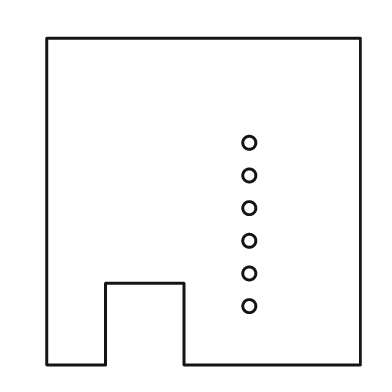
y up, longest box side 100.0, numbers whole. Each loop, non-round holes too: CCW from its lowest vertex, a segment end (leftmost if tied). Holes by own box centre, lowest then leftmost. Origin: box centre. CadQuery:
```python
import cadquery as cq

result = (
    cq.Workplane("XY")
    .moveTo(-48.0, -50.0)
    .lineTo(-30.0, -50.0)
    .lineTo(-30.0, -25.0)
    .lineTo(-6.0, -25.0)
    .lineTo(-6.0, -50.0)
    .lineTo(48.0, -50.0)
    .lineTo(48.0, 50.0)
    .lineTo(-48.0, 50.0)
    .close()
    .moveTo(14.0, -32.0)
    .circle(2.0)
    .moveTo(14.0, -22.0)
    .circle(2.0)
    .moveTo(14.0, -12.0)
    .circle(2.0)
    .moveTo(14.0, -2.0)
    .circle(2.0)
    .moveTo(14.0, 8.0)
    .circle(2.0)
    .moveTo(14.0, 18.0)
    .circle(2.0)
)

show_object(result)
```